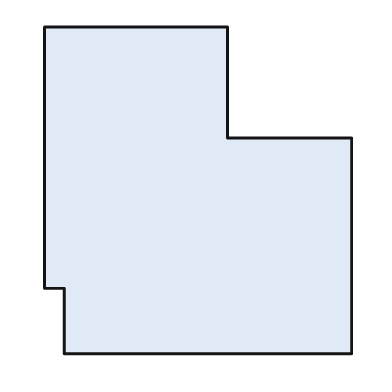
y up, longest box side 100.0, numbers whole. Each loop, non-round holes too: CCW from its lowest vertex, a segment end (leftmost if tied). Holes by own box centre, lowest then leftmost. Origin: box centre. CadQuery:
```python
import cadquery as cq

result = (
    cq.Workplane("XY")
    .moveTo(-41.0, -50.0)
    .lineTo(47.0, -50.0)
    .lineTo(47.0, 16.0)
    .lineTo(9.0, 16.0)
    .lineTo(9.0, 50.0)
    .lineTo(-47.0, 50.0)
    .lineTo(-47.0, -30.0)
    .lineTo(-41.0, -30.0)
    .close()
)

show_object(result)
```